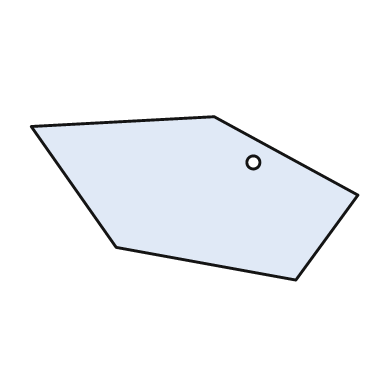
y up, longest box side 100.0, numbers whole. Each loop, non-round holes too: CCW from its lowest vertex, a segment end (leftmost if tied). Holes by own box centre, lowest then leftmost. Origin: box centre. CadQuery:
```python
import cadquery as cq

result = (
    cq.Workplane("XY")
    .moveTo(31.0, -25.0)
    .lineTo(50.0, 1.0)
    .lineTo(6.0, 25.0)
    .lineTo(-50.0, 22.0)
    .lineTo(-24.0, -15.0)
    .close()
    .moveTo(18.0, 11.0)
    .circle(2.0)
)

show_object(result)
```